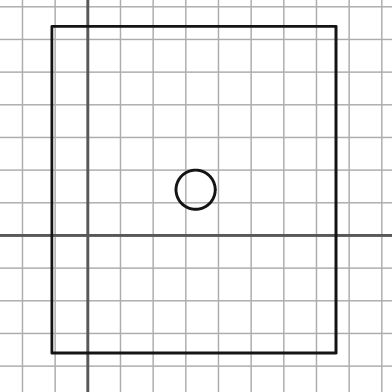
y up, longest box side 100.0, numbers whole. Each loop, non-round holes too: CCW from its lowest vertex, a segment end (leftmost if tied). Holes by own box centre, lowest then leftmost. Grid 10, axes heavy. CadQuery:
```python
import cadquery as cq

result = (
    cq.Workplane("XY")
    .moveTo(-11.0, -36.0)
    .lineTo(76.0, -36.0)
    .lineTo(76.0, 64.0)
    .lineTo(-11.0, 64.0)
    .close()
    .moveTo(33.0, 14.0)
    .circle(6.0)
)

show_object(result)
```